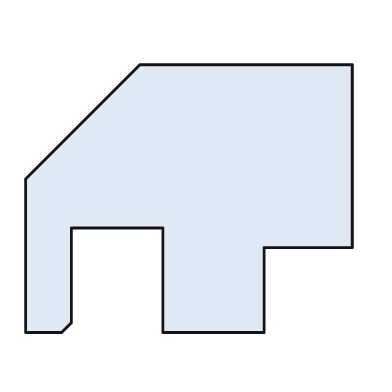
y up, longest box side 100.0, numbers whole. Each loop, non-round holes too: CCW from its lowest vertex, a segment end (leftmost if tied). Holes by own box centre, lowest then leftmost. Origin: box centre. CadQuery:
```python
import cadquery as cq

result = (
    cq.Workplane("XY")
    .moveTo(-50.0, -41.0)
    .lineTo(-39.0, -41.0)
    .lineTo(-36.0, -38.0)
    .lineTo(-36.0, -9.0)
    .lineTo(-8.0, -9.0)
    .lineTo(-8.0, -41.0)
    .lineTo(23.0, -41.0)
    .lineTo(23.0, -15.0)
    .lineTo(50.0, -15.0)
    .lineTo(50.0, 41.0)
    .lineTo(-15.0, 41.0)
    .lineTo(-50.0, 6.0)
    .close()
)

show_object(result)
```